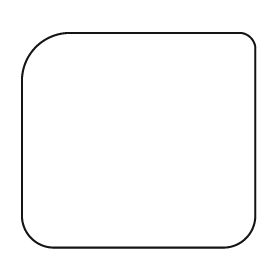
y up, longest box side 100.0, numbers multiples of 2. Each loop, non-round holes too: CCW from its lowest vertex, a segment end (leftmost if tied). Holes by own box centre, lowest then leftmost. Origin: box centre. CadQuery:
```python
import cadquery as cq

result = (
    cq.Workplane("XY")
    .moveTo(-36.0, -46.0)
    .lineTo(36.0, -46.0)
    .threePointArc((46.0, -42.0), (50.0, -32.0))
    .lineTo(50.0, 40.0)
    .threePointArc((48.0, 44.0), (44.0, 46.0))
    .lineTo(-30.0, 46.0)
    .threePointArc((-44.0, 40.0), (-50.0, 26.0))
    .lineTo(-50.0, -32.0)
    .threePointArc((-46.0, -42.0), (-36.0, -46.0))
    .close()
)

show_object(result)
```